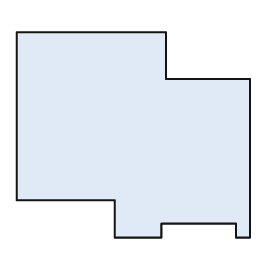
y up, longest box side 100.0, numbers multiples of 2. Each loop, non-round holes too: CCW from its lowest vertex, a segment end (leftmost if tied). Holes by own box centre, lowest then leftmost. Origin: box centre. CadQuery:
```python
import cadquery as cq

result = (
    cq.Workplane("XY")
    .moveTo(-8.0, -44.0)
    .lineTo(12.0, -44.0)
    .lineTo(12.0, -38.0)
    .lineTo(44.0, -38.0)
    .lineTo(44.0, -44.0)
    .lineTo(50.0, -44.0)
    .lineTo(50.0, 24.0)
    .lineTo(14.0, 24.0)
    .lineTo(14.0, 44.0)
    .lineTo(-50.0, 44.0)
    .lineTo(-50.0, -28.0)
    .lineTo(-8.0, -28.0)
    .close()
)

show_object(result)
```